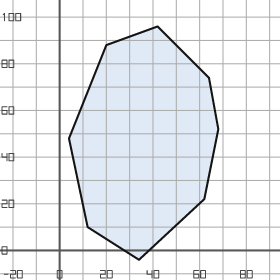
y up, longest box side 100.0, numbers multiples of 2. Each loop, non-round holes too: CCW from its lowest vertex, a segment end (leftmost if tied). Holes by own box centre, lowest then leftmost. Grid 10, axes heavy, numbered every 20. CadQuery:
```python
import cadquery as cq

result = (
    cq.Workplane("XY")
    .moveTo(34.0, -4.0)
    .lineTo(62.0, 22.0)
    .lineTo(68.0, 52.0)
    .lineTo(64.0, 74.0)
    .lineTo(42.0, 96.0)
    .lineTo(20.0, 88.0)
    .lineTo(4.0, 48.0)
    .lineTo(12.0, 10.0)
    .close()
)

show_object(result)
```